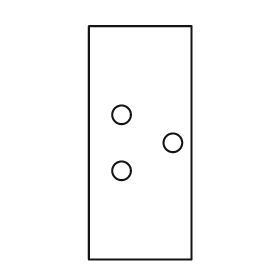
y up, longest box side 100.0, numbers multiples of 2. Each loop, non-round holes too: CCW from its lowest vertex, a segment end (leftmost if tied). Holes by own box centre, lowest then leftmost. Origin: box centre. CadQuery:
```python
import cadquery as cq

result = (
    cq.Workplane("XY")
    .moveTo(-22.0, -50.0)
    .lineTo(22.0, -50.0)
    .lineTo(22.0, 50.0)
    .lineTo(-22.0, 50.0)
    .close()
    .moveTo(-8.0, -12.0)
    .circle(4.0)
    .moveTo(14.0, 0.0)
    .circle(4.0)
    .moveTo(-8.0, 12.0)
    .circle(4.0)
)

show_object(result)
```